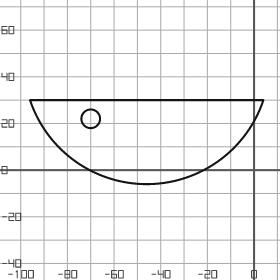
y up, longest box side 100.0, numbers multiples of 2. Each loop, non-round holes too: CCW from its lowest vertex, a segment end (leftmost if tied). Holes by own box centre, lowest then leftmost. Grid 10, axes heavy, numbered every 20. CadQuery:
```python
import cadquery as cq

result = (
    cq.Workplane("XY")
    .moveTo(-96.0, 30.0)
    .threePointArc((-46.0, -6.0), (4.0, 30.0))
    .close()
    .moveTo(-70.0, 22.0)
    .circle(4.0)
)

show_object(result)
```